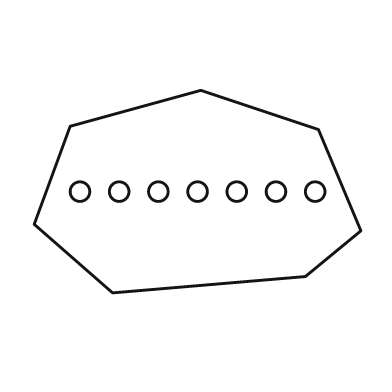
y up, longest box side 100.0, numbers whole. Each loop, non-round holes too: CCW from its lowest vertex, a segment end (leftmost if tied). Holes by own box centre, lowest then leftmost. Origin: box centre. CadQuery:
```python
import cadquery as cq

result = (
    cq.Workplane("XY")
    .moveTo(-26.0, -31.0)
    .lineTo(33.0, -26.0)
    .lineTo(50.0, -12.0)
    .lineTo(37.0, 19.0)
    .lineTo(1.0, 31.0)
    .lineTo(-39.0, 20.0)
    .lineTo(-50.0, -10.0)
    .close()
    .moveTo(-36.0, 0.0)
    .circle(3.0)
    .moveTo(-24.0, 0.0)
    .circle(3.0)
    .moveTo(-12.0, 0.0)
    .circle(3.0)
    .moveTo(0.0, 0.0)
    .circle(3.0)
    .moveTo(12.0, 0.0)
    .circle(3.0)
    .moveTo(24.0, 0.0)
    .circle(3.0)
    .moveTo(36.0, 0.0)
    .circle(3.0)
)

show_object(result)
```